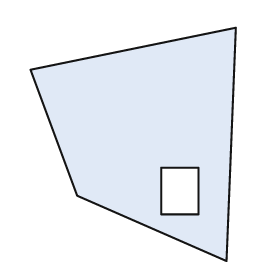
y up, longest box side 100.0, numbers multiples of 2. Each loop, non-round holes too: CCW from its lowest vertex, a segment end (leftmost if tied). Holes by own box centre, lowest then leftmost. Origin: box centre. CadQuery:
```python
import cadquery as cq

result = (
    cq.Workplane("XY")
    .moveTo(40.0, -50.0)
    .lineTo(44.0, 50.0)
    .lineTo(-44.0, 32.0)
    .lineTo(-24.0, -22.0)
    .close()
    .moveTo(12.0, -30.0)
    .lineTo(28.0, -30.0)
    .lineTo(28.0, -10.0)
    .lineTo(12.0, -10.0)
    .close()
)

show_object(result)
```